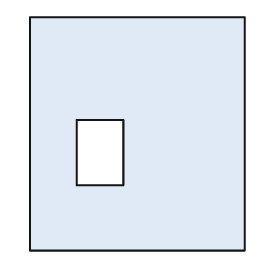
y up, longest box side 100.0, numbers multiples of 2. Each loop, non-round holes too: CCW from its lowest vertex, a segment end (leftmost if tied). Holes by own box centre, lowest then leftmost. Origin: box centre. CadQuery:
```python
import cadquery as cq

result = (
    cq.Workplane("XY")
    .moveTo(-46.0, -50.0)
    .lineTo(46.0, -50.0)
    .lineTo(46.0, 50.0)
    .lineTo(-46.0, 50.0)
    .close()
    .moveTo(-26.0, -22.0)
    .lineTo(-6.0, -22.0)
    .lineTo(-6.0, 6.0)
    .lineTo(-26.0, 6.0)
    .close()
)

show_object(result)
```